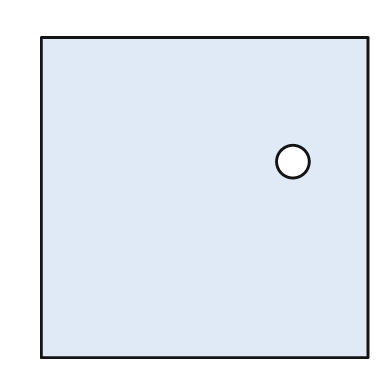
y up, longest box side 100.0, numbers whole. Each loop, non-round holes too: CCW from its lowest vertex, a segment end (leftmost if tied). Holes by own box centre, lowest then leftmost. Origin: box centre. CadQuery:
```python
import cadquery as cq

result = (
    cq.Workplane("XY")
    .moveTo(-50.0, -49.0)
    .lineTo(50.0, -49.0)
    .lineTo(50.0, 49.0)
    .lineTo(-50.0, 49.0)
    .close()
    .moveTo(27.0, 11.0)
    .circle(5.0)
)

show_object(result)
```